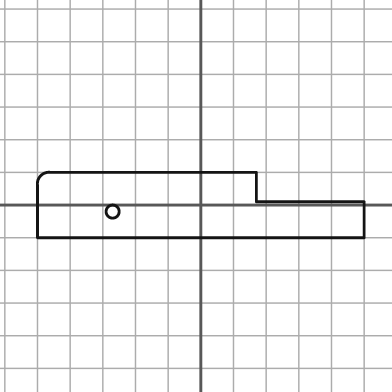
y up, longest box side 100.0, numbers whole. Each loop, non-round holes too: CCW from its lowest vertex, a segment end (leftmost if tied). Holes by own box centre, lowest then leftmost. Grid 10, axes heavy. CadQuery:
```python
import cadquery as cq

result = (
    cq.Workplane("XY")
    .moveTo(-50.0, -10.0)
    .lineTo(50.0, -10.0)
    .lineTo(50.0, 1.0)
    .lineTo(17.0, 1.0)
    .lineTo(17.0, 10.0)
    .lineTo(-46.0, 10.0)
    .threePointArc((-49.0, 9.0), (-50.0, 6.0))
    .close()
    .moveTo(-27.0, -2.0)
    .circle(2.0)
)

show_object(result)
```